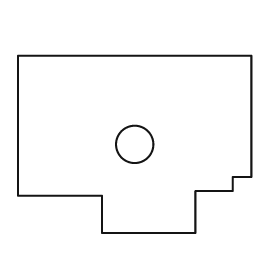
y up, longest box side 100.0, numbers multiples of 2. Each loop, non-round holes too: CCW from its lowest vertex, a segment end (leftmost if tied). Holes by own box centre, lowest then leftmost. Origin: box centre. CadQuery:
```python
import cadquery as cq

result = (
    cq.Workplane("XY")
    .moveTo(-14.0, -38.0)
    .lineTo(26.0, -38.0)
    .lineTo(26.0, -20.0)
    .lineTo(42.0, -20.0)
    .lineTo(42.0, -14.0)
    .lineTo(50.0, -14.0)
    .lineTo(50.0, 38.0)
    .lineTo(-50.0, 38.0)
    .lineTo(-50.0, -22.0)
    .lineTo(-14.0, -22.0)
    .close()
    .moveTo(0.0, 0.0)
    .circle(8.0)
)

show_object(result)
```